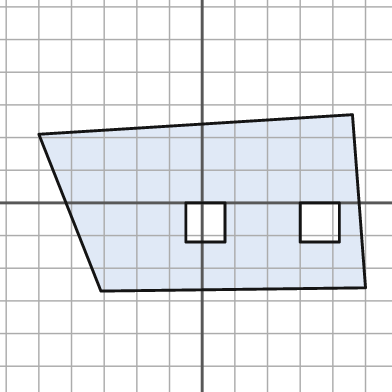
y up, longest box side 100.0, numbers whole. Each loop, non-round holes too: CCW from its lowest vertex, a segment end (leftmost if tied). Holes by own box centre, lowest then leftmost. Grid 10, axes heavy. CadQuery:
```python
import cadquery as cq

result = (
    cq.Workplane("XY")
    .moveTo(-31.0, -27.0)
    .lineTo(50.0, -26.0)
    .lineTo(46.0, 27.0)
    .lineTo(-50.0, 21.0)
    .close()
    .moveTo(-5.0, -12.0)
    .lineTo(7.0, -12.0)
    .lineTo(7.0, 0.0)
    .lineTo(-5.0, 0.0)
    .close()
    .moveTo(30.0, -12.0)
    .lineTo(42.0, -12.0)
    .lineTo(42.0, 0.0)
    .lineTo(30.0, 0.0)
    .close()
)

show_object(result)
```